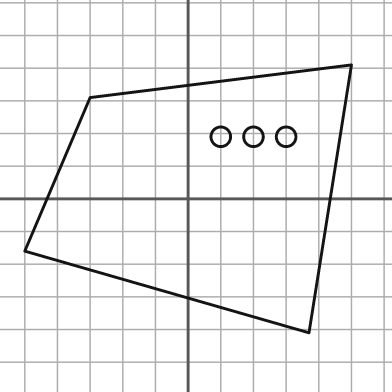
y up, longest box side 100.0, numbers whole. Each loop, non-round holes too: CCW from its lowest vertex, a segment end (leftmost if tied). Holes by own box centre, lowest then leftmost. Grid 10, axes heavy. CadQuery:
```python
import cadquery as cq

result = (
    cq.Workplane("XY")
    .moveTo(37.0, -41.0)
    .lineTo(50.0, 41.0)
    .lineTo(-30.0, 31.0)
    .lineTo(-50.0, -16.0)
    .close()
    .moveTo(10.0, 19.0)
    .circle(3.0)
    .moveTo(20.0, 19.0)
    .circle(3.0)
    .moveTo(30.0, 19.0)
    .circle(3.0)
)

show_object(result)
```